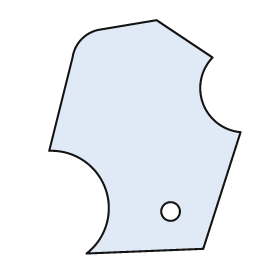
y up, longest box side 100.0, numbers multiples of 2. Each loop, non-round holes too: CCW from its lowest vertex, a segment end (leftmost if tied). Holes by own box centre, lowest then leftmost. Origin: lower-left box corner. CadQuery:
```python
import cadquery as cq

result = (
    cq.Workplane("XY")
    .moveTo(16.0, 0.0)
    .lineTo(66.0, 2.0)
    .lineTo(82.0, 52.0)
    .threePointArc((66.0, 64.0), (70.0, 84.0))
    .lineTo(46.0, 100.0)
    .lineTo(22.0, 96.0)
    .threePointArc((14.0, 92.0), (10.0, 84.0))
    .lineTo(0.0, 44.0)
    .threePointArc((24.0, 28.0), (16.0, 0.0))
    .close()
    .moveTo(52.0, 18.0)
    .circle(4.0)
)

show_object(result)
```